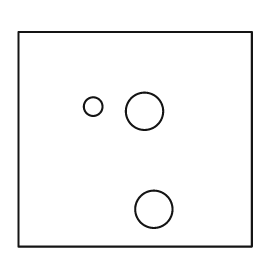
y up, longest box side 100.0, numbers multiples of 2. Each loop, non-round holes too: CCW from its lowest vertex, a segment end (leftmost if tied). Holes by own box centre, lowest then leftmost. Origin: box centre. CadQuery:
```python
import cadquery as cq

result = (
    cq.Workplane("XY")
    .moveTo(-50.0, -46.0)
    .lineTo(50.0, -46.0)
    .lineTo(50.0, 46.0)
    .lineTo(-50.0, 46.0)
    .close()
    .moveTo(8.0, -30.0)
    .circle(8.0)
    .moveTo(4.0, 12.0)
    .circle(8.0)
    .moveTo(-18.0, 14.0)
    .circle(4.0)
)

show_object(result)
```